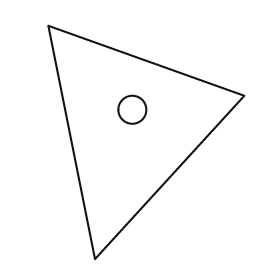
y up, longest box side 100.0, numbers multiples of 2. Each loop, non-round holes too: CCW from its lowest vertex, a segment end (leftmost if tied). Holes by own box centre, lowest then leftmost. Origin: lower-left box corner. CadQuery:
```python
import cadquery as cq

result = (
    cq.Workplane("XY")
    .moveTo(20.0, 0.0)
    .lineTo(84.0, 70.0)
    .lineTo(0.0, 100.0)
    .close()
    .moveTo(36.0, 64.0)
    .circle(6.0)
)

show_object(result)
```